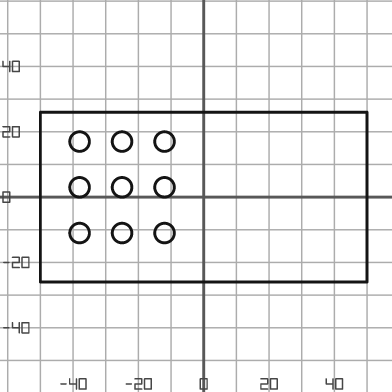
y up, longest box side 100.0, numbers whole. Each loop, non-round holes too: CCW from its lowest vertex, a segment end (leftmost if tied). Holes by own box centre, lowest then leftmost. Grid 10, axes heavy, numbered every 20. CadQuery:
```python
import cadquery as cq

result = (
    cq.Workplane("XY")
    .moveTo(-50.0, -26.0)
    .lineTo(50.0, -26.0)
    .lineTo(50.0, 26.0)
    .lineTo(-50.0, 26.0)
    .close()
    .moveTo(-38.0, -11.0)
    .circle(3.0)
    .moveTo(-25.0, -11.0)
    .circle(3.0)
    .moveTo(-12.0, -11.0)
    .circle(3.0)
    .moveTo(-38.0, 3.0)
    .circle(3.0)
    .moveTo(-25.0, 3.0)
    .circle(3.0)
    .moveTo(-12.0, 3.0)
    .circle(3.0)
    .moveTo(-38.0, 17.0)
    .circle(3.0)
    .moveTo(-25.0, 17.0)
    .circle(3.0)
    .moveTo(-12.0, 17.0)
    .circle(3.0)
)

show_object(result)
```